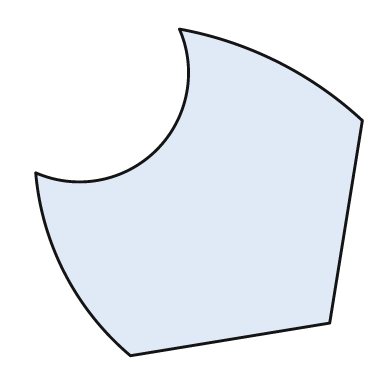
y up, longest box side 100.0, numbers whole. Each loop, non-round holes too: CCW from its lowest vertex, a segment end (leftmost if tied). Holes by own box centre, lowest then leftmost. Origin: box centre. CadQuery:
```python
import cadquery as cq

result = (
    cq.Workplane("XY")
    .moveTo(-21.0, -50.0)
    .lineTo(40.0, -40.0)
    .lineTo(50.0, 22.0)
    .threePointArc((24.0, 40.0), (-6.0, 50.0))
    .threePointArc((-13.0, 13.0), (-50.0, 6.0))
    .threePointArc((-41.0, -25.0), (-21.0, -50.0))
    .close()
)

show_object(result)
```